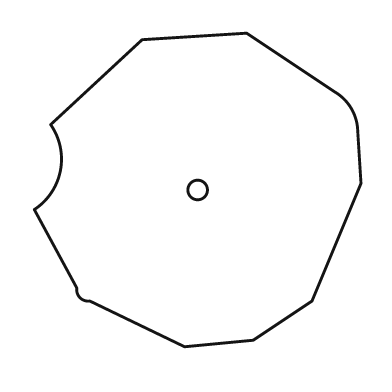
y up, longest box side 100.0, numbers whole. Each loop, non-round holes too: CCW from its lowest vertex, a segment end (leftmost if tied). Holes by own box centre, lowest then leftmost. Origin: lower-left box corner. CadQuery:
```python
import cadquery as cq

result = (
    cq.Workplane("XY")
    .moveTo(46.0, 0.0)
    .lineTo(67.0, 2.0)
    .lineTo(85.0, 14.0)
    .lineTo(100.0, 50.0)
    .lineTo(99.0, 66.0)
    .threePointArc((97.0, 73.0), (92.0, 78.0))
    .lineTo(65.0, 96.0)
    .lineTo(33.0, 94.0)
    .lineTo(5.0, 68.0)
    .threePointArc((8.0, 54.0), (0.0, 42.0))
    .lineTo(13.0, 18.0)
    .threePointArc((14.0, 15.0), (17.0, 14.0))
    .close()
    .moveTo(50.0, 48.0)
    .circle(3.0)
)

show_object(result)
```